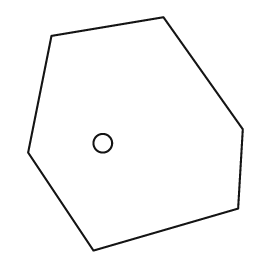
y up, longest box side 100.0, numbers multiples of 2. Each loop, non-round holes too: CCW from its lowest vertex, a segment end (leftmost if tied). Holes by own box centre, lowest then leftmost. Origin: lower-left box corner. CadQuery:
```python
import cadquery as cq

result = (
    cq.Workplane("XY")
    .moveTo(28.0, 0.0)
    .lineTo(90.0, 18.0)
    .lineTo(92.0, 52.0)
    .lineTo(58.0, 100.0)
    .lineTo(10.0, 92.0)
    .lineTo(0.0, 42.0)
    .close()
    .moveTo(32.0, 46.0)
    .circle(4.0)
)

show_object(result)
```